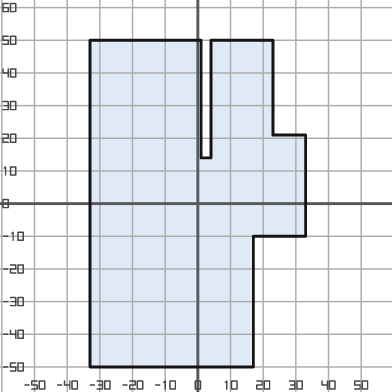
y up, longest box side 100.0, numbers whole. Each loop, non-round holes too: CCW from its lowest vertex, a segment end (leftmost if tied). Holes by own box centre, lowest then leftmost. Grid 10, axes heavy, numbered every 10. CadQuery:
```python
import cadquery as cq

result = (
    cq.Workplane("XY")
    .moveTo(-33.0, -50.0)
    .lineTo(17.0, -50.0)
    .lineTo(17.0, -10.0)
    .lineTo(33.0, -10.0)
    .lineTo(33.0, 21.0)
    .lineTo(23.0, 21.0)
    .lineTo(23.0, 50.0)
    .lineTo(4.0, 50.0)
    .lineTo(4.0, 14.0)
    .lineTo(1.0, 14.0)
    .lineTo(1.0, 50.0)
    .lineTo(-33.0, 50.0)
    .close()
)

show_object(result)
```